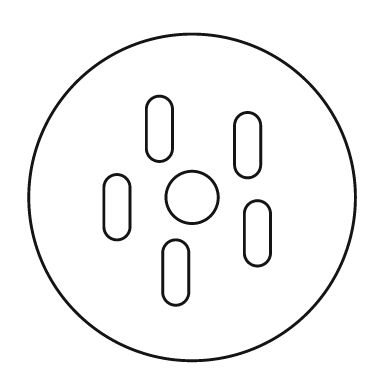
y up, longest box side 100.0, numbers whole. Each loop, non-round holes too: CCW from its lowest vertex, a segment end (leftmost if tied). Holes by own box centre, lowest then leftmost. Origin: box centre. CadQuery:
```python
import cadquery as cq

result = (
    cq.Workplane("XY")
    .moveTo(0.0, 0.0)
    .circle(50.0)
    .moveTo(-9.0, -29.0)
    .threePointArc((-5.0, -33.0), (-1.0, -29.0))
    .lineTo(-1.0, -17.0)
    .threePointArc((-5.0, -13.0), (-9.0, -17.0))
    .close()
    .moveTo(16.0, -17.0)
    .threePointArc((20.0, -21.0), (24.0, -17.0))
    .lineTo(24.0, -5.0)
    .threePointArc((20.0, -1.0), (16.0, -5.0))
    .close()
    .moveTo(-27.0, -9.0)
    .threePointArc((-23.0, -13.0), (-19.0, -9.0))
    .lineTo(-19.0, 3.0)
    .threePointArc((-23.0, 7.0), (-27.0, 3.0))
    .close()
    .moveTo(0.0, 0.0)
    .circle(8.0)
    .moveTo(13.0, 10.0)
    .threePointArc((17.0, 6.0), (21.0, 10.0))
    .lineTo(21.0, 22.0)
    .threePointArc((17.0, 26.0), (13.0, 22.0))
    .close()
    .moveTo(-14.0, 15.0)
    .threePointArc((-10.0, 11.0), (-6.0, 15.0))
    .lineTo(-6.0, 27.0)
    .threePointArc((-10.0, 31.0), (-14.0, 27.0))
    .close()
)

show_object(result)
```